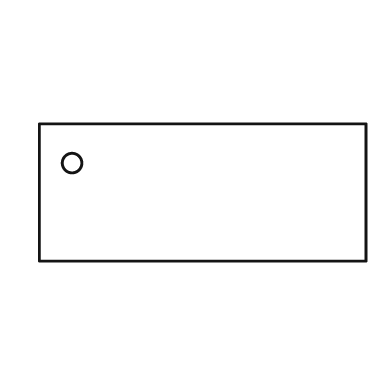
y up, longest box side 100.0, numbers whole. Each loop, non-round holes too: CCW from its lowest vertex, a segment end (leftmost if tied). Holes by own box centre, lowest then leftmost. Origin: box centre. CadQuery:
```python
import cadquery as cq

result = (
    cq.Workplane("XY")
    .moveTo(-50.0, -21.0)
    .lineTo(50.0, -21.0)
    .lineTo(50.0, 21.0)
    .lineTo(-50.0, 21.0)
    .close()
    .moveTo(-40.0, 9.0)
    .circle(3.0)
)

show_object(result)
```